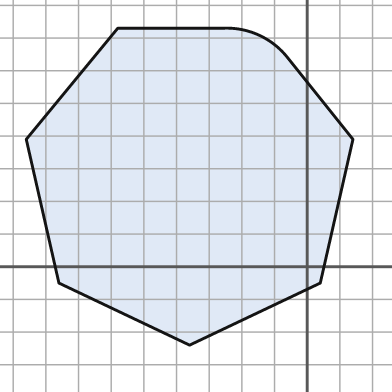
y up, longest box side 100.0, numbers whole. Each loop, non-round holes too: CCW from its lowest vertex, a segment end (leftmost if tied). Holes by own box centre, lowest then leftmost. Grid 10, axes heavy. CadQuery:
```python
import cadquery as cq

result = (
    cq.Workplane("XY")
    .moveTo(-36.0, -24.0)
    .lineTo(4.0, -5.0)
    .lineTo(14.0, 39.0)
    .lineTo(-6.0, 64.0)
    .threePointArc((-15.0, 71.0), (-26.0, 73.0))
    .lineTo(-58.0, 73.0)
    .lineTo(-86.0, 39.0)
    .lineTo(-76.0, -5.0)
    .close()
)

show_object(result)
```